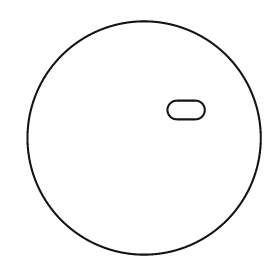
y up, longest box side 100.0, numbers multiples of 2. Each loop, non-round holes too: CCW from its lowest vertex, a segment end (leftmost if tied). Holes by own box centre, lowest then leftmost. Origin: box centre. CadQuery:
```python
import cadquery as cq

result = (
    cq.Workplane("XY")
    .moveTo(0.0, 0.0)
    .circle(50.0)
    .moveTo(14.0, 8.0)
    .lineTo(22.0, 8.0)
    .threePointArc((26.0, 12.0), (22.0, 16.0))
    .lineTo(14.0, 16.0)
    .threePointArc((10.0, 12.0), (14.0, 8.0))
    .close()
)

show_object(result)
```